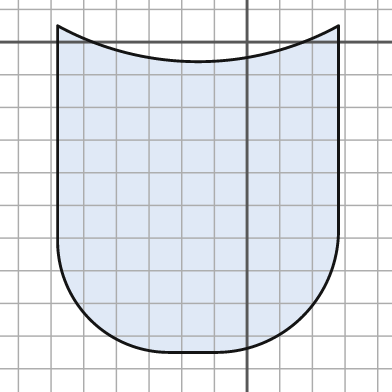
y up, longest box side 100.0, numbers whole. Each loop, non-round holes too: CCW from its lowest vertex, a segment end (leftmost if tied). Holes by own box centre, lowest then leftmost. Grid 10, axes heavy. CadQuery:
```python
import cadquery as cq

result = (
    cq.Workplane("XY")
    .moveTo(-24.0, -95.0)
    .lineTo(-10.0, -95.0)
    .threePointArc((17.0, -84.0), (28.0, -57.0))
    .lineTo(28.0, 5.0)
    .threePointArc((-15.0, -6.0), (-58.0, 5.0))
    .lineTo(-58.0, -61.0)
    .threePointArc((-48.0, -85.0), (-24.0, -95.0))
    .close()
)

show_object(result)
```